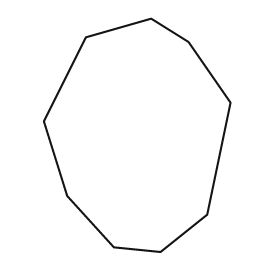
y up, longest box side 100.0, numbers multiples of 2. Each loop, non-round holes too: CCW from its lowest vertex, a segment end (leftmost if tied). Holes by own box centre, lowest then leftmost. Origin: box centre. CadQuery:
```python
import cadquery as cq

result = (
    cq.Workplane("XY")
    .moveTo(10.0, -50.0)
    .lineTo(30.0, -34.0)
    .lineTo(40.0, 14.0)
    .lineTo(22.0, 40.0)
    .lineTo(6.0, 50.0)
    .lineTo(-22.0, 42.0)
    .lineTo(-40.0, 6.0)
    .lineTo(-30.0, -26.0)
    .lineTo(-10.0, -48.0)
    .close()
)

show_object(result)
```